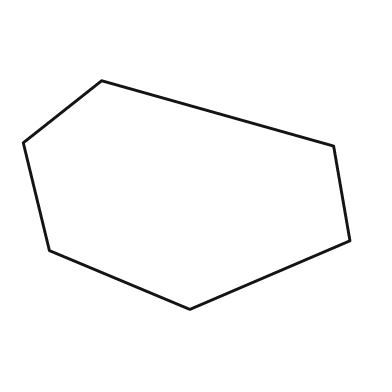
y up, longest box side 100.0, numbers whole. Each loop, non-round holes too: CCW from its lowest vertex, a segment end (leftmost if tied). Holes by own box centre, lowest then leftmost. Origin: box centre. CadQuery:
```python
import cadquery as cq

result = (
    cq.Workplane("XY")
    .moveTo(1.0, -35.0)
    .lineTo(50.0, -14.0)
    .lineTo(45.0, 15.0)
    .lineTo(-26.0, 35.0)
    .lineTo(-50.0, 16.0)
    .lineTo(-42.0, -17.0)
    .close()
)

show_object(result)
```